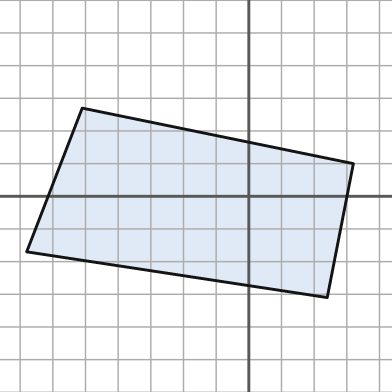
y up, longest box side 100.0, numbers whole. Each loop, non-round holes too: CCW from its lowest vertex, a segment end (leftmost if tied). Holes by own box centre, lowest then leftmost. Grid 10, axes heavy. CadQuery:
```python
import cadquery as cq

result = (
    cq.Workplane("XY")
    .moveTo(24.0, -31.0)
    .lineTo(32.0, 10.0)
    .lineTo(-51.0, 27.0)
    .lineTo(-68.0, -17.0)
    .close()
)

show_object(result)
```